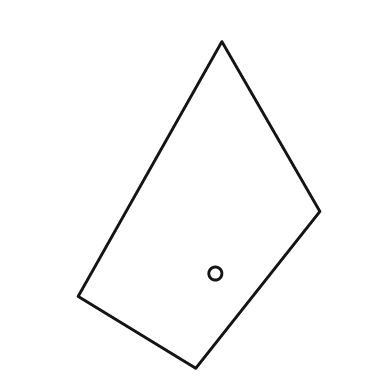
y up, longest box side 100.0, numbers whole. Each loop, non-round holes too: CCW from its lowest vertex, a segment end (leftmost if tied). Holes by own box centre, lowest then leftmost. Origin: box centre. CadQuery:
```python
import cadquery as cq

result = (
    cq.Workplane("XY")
    .moveTo(-1.0, -50.0)
    .lineTo(37.0, -2.0)
    .lineTo(7.0, 50.0)
    .lineTo(-37.0, -28.0)
    .close()
    .moveTo(5.0, -21.0)
    .circle(2.0)
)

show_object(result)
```